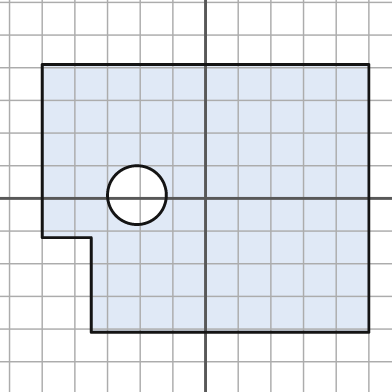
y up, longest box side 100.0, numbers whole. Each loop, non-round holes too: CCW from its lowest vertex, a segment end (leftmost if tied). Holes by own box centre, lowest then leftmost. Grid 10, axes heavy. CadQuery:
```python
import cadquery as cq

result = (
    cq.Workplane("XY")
    .moveTo(-35.0, -41.0)
    .lineTo(50.0, -41.0)
    .lineTo(50.0, 41.0)
    .lineTo(-50.0, 41.0)
    .lineTo(-50.0, -12.0)
    .lineTo(-35.0, -12.0)
    .close()
    .moveTo(-21.0, 1.0)
    .circle(9.0)
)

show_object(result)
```